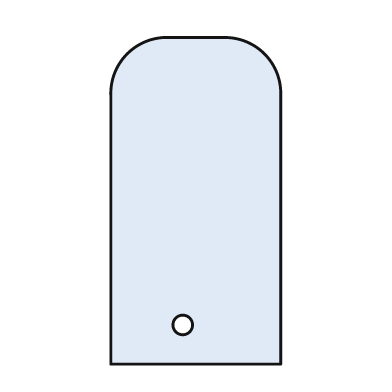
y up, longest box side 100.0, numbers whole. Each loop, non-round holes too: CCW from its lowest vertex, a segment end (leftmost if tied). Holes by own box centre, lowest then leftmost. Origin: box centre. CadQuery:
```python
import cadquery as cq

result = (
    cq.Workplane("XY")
    .moveTo(-26.0, -50.0)
    .lineTo(26.0, -50.0)
    .lineTo(26.0, 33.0)
    .threePointArc((21.0, 45.0), (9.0, 50.0))
    .lineTo(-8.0, 50.0)
    .threePointArc((-21.0, 45.0), (-26.0, 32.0))
    .close()
    .moveTo(-4.0, -38.0)
    .circle(3.0)
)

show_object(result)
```